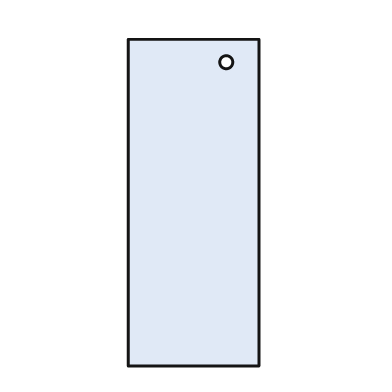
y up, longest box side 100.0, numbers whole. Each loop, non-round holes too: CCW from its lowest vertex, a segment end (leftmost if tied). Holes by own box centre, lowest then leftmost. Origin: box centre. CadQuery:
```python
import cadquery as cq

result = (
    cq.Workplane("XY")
    .moveTo(-20.0, -50.0)
    .lineTo(20.0, -50.0)
    .lineTo(20.0, 50.0)
    .lineTo(-20.0, 50.0)
    .close()
    .moveTo(10.0, 43.0)
    .circle(2.0)
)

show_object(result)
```